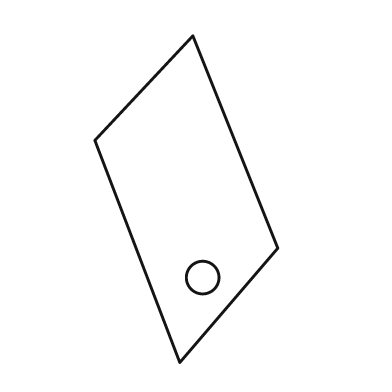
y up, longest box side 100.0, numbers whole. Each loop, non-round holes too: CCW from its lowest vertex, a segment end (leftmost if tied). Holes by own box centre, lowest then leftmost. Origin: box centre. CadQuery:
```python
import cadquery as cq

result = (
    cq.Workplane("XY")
    .moveTo(-2.0, -50.0)
    .lineTo(28.0, -15.0)
    .lineTo(2.0, 50.0)
    .lineTo(-28.0, 18.0)
    .close()
    .moveTo(5.0, -24.0)
    .circle(5.0)
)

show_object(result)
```